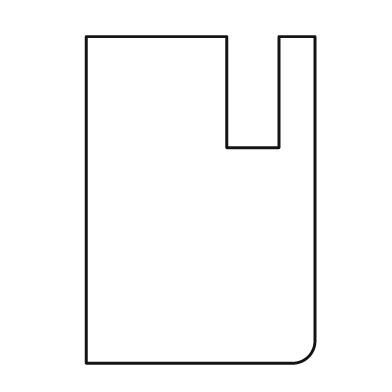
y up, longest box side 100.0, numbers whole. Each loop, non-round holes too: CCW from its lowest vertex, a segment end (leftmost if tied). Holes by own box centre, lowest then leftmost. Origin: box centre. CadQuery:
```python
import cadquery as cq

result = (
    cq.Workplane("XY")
    .moveTo(-35.0, -50.0)
    .lineTo(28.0, -50.0)
    .threePointArc((33.0, -48.0), (35.0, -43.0))
    .lineTo(35.0, 50.0)
    .lineTo(24.0, 50.0)
    .lineTo(24.0, 16.0)
    .lineTo(8.0, 16.0)
    .lineTo(8.0, 50.0)
    .lineTo(-35.0, 50.0)
    .close()
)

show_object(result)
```